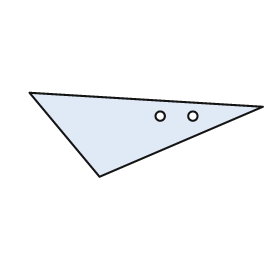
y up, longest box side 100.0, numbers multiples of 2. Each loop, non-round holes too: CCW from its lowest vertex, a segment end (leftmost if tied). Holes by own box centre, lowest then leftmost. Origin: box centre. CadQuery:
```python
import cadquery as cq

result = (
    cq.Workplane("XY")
    .moveTo(-20.0, -18.0)
    .lineTo(50.0, 12.0)
    .lineTo(-50.0, 18.0)
    .close()
    .moveTo(6.0, 8.0)
    .circle(2.0)
    .moveTo(20.0, 8.0)
    .circle(2.0)
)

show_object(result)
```